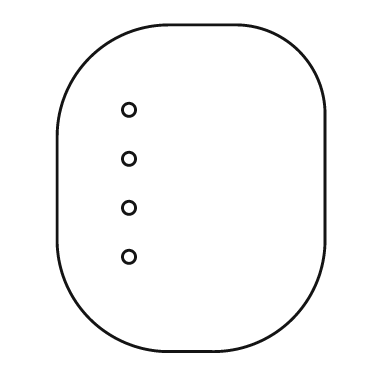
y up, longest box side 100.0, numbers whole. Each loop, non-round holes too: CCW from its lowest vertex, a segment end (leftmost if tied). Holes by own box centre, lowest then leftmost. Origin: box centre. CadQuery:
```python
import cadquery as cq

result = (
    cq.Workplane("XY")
    .moveTo(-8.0, -50.0)
    .lineTo(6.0, -50.0)
    .threePointArc((31.0, -40.0), (41.0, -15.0))
    .lineTo(41.0, 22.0)
    .threePointArc((33.0, 42.0), (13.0, 50.0))
    .lineTo(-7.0, 50.0)
    .threePointArc((-31.0, 40.0), (-41.0, 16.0))
    .lineTo(-41.0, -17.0)
    .threePointArc((-31.0, -40.0), (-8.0, -50.0))
    .close()
    .moveTo(-19.0, -21.0)
    .circle(2.0)
    .moveTo(-19.0, -6.0)
    .circle(2.0)
    .moveTo(-19.0, 9.0)
    .circle(2.0)
    .moveTo(-19.0, 24.0)
    .circle(2.0)
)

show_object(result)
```